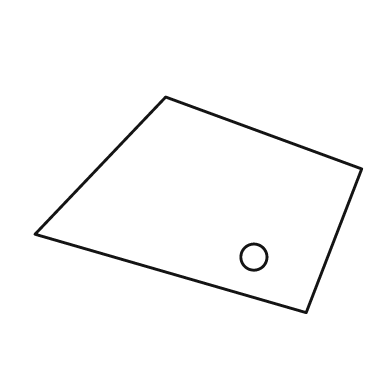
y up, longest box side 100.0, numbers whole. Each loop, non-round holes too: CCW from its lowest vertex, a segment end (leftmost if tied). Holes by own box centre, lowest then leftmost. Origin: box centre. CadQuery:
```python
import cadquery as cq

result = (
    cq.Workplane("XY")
    .moveTo(33.0, -33.0)
    .lineTo(50.0, 11.0)
    .lineTo(-10.0, 33.0)
    .lineTo(-50.0, -9.0)
    .close()
    .moveTo(17.0, -16.0)
    .circle(4.0)
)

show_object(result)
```